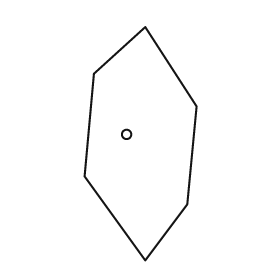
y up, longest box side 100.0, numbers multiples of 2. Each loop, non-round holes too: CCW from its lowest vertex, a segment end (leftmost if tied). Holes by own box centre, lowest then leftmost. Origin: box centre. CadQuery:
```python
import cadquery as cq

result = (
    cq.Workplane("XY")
    .moveTo(2.0, -50.0)
    .lineTo(20.0, -26.0)
    .lineTo(24.0, 16.0)
    .lineTo(2.0, 50.0)
    .lineTo(-20.0, 30.0)
    .lineTo(-24.0, -14.0)
    .close()
    .moveTo(-6.0, 4.0)
    .circle(2.0)
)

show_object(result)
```